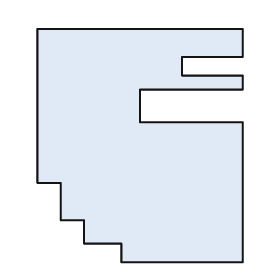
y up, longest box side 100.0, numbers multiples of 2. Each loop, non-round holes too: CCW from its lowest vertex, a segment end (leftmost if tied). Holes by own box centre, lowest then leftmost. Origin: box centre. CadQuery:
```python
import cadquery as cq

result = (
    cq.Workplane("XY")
    .moveTo(-8.0, -50.0)
    .lineTo(44.0, -50.0)
    .lineTo(44.0, 10.0)
    .lineTo(0.0, 10.0)
    .lineTo(0.0, 24.0)
    .lineTo(44.0, 24.0)
    .lineTo(44.0, 30.0)
    .lineTo(18.0, 30.0)
    .lineTo(18.0, 38.0)
    .lineTo(44.0, 38.0)
    .lineTo(44.0, 50.0)
    .lineTo(-44.0, 50.0)
    .lineTo(-44.0, -16.0)
    .lineTo(-34.0, -16.0)
    .lineTo(-34.0, -32.0)
    .lineTo(-24.0, -32.0)
    .lineTo(-24.0, -42.0)
    .lineTo(-8.0, -42.0)
    .close()
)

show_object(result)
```